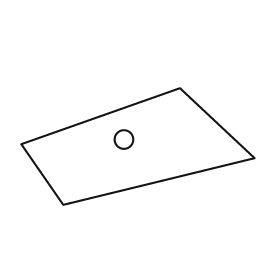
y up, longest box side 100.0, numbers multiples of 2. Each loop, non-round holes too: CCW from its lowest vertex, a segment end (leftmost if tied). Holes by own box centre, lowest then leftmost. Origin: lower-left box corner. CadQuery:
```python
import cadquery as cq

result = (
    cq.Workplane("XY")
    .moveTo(18.0, 0.0)
    .lineTo(100.0, 20.0)
    .lineTo(68.0, 50.0)
    .lineTo(0.0, 26.0)
    .close()
    .moveTo(44.0, 28.0)
    .circle(4.0)
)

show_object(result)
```